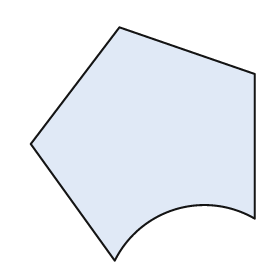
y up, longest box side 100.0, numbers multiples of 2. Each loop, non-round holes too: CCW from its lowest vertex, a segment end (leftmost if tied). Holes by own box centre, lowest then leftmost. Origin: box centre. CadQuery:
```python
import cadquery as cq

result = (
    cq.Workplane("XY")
    .moveTo(-12.0, -50.0)
    .threePointArc((14.0, -28.0), (48.0, -32.0))
    .lineTo(48.0, 30.0)
    .lineTo(-10.0, 50.0)
    .lineTo(-48.0, 0.0)
    .close()
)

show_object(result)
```